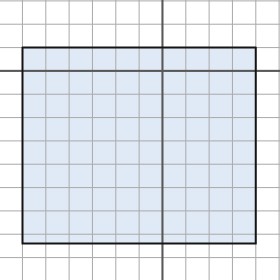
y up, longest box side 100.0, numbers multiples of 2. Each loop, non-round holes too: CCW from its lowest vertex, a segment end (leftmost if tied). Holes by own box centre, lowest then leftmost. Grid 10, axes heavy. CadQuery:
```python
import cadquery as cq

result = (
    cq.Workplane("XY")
    .moveTo(-60.0, -74.0)
    .lineTo(40.0, -74.0)
    .lineTo(40.0, 10.0)
    .lineTo(-60.0, 10.0)
    .close()
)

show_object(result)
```